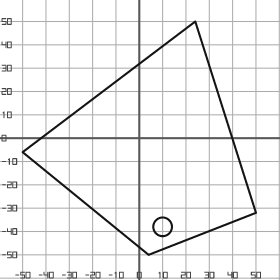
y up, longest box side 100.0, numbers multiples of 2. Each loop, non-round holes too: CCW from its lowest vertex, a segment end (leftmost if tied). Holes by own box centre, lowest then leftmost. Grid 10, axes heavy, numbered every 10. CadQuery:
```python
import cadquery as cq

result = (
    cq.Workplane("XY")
    .moveTo(4.0, -50.0)
    .lineTo(50.0, -32.0)
    .lineTo(24.0, 50.0)
    .lineTo(-50.0, -6.0)
    .close()
    .moveTo(10.0, -38.0)
    .circle(4.0)
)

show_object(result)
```